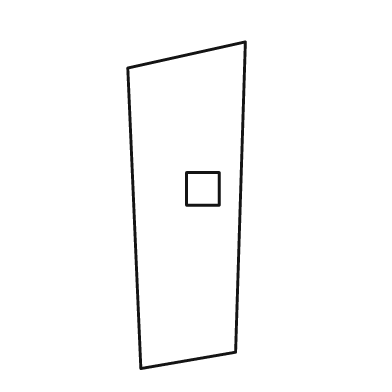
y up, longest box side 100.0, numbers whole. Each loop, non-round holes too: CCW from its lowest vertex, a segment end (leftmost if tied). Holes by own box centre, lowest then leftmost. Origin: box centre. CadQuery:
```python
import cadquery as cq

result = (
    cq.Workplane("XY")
    .moveTo(-14.0, -50.0)
    .lineTo(15.0, -45.0)
    .lineTo(18.0, 50.0)
    .lineTo(-18.0, 42.0)
    .close()
    .moveTo(0.0, 0.0)
    .lineTo(10.0, 0.0)
    .lineTo(10.0, 10.0)
    .lineTo(0.0, 10.0)
    .close()
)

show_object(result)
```